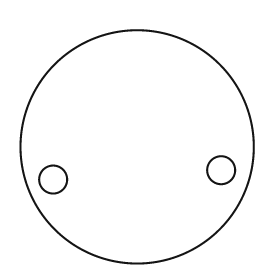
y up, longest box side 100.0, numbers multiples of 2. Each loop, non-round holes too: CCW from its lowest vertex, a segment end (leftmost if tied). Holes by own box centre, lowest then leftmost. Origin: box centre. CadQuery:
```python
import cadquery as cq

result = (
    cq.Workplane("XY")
    .moveTo(0.0, 0.0)
    .circle(50.0)
    .moveTo(-36.0, -14.0)
    .circle(6.0)
    .moveTo(36.0, -10.0)
    .circle(6.0)
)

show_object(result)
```